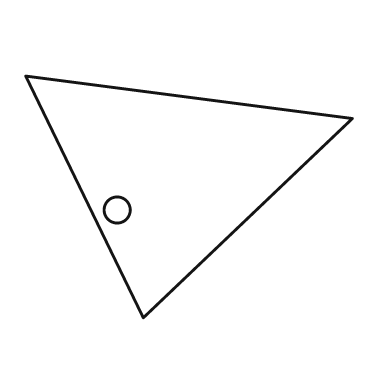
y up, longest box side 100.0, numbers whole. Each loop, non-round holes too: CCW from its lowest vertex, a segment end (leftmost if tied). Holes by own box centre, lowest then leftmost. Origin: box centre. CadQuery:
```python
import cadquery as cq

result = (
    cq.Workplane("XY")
    .moveTo(-14.0, -37.0)
    .lineTo(50.0, 24.0)
    .lineTo(-50.0, 37.0)
    .close()
    .moveTo(-22.0, -4.0)
    .circle(4.0)
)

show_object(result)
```